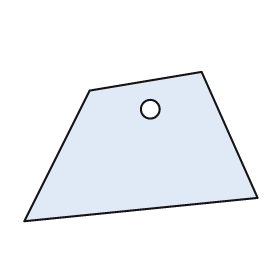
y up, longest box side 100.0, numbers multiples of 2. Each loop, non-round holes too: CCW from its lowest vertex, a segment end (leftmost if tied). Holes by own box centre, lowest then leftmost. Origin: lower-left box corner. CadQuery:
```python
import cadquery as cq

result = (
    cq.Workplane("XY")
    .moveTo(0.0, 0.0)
    .lineTo(100.0, 10.0)
    .lineTo(76.0, 64.0)
    .lineTo(28.0, 56.0)
    .close()
    .moveTo(54.0, 48.0)
    .circle(4.0)
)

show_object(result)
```